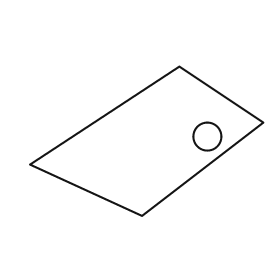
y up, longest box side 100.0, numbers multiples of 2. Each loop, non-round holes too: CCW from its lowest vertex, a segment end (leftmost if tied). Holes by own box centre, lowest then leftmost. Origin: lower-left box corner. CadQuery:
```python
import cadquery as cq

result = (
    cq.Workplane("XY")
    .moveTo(48.0, 0.0)
    .lineTo(100.0, 40.0)
    .lineTo(64.0, 64.0)
    .lineTo(0.0, 22.0)
    .close()
    .moveTo(76.0, 34.0)
    .circle(6.0)
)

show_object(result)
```